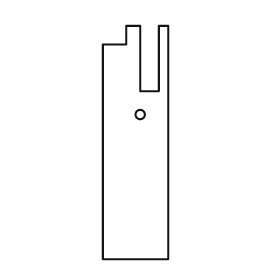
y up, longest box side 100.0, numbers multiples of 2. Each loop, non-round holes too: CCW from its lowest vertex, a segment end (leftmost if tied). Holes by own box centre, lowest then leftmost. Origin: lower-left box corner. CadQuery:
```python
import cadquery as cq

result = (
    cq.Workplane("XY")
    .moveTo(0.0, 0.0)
    .lineTo(28.0, 0.0)
    .lineTo(28.0, 100.0)
    .lineTo(24.0, 100.0)
    .lineTo(24.0, 72.0)
    .lineTo(16.0, 72.0)
    .lineTo(16.0, 100.0)
    .lineTo(10.0, 100.0)
    .lineTo(10.0, 92.0)
    .lineTo(0.0, 92.0)
    .close()
    .moveTo(16.0, 62.0)
    .circle(2.0)
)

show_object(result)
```